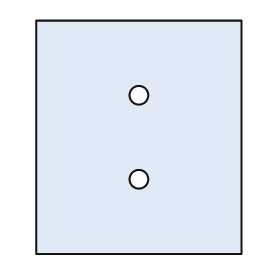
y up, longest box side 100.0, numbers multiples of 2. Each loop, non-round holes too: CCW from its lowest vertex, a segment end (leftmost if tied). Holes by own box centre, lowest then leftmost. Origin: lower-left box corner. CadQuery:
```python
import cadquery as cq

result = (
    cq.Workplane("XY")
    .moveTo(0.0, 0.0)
    .lineTo(88.0, 0.0)
    .lineTo(88.0, 100.0)
    .lineTo(0.0, 100.0)
    .close()
    .moveTo(44.0, 32.0)
    .circle(4.0)
    .moveTo(44.0, 68.0)
    .circle(4.0)
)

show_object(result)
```